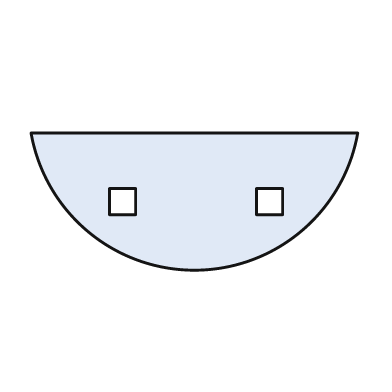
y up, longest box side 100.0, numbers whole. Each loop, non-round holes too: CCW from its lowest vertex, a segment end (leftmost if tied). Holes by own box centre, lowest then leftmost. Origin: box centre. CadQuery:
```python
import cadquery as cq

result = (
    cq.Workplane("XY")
    .moveTo(-50.0, 21.0)
    .threePointArc((0.0, -21.0), (50.0, 21.0))
    .close()
    .moveTo(-26.0, -4.0)
    .lineTo(-18.0, -4.0)
    .lineTo(-18.0, 4.0)
    .lineTo(-26.0, 4.0)
    .close()
    .moveTo(19.0, -4.0)
    .lineTo(27.0, -4.0)
    .lineTo(27.0, 4.0)
    .lineTo(19.0, 4.0)
    .close()
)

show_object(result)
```